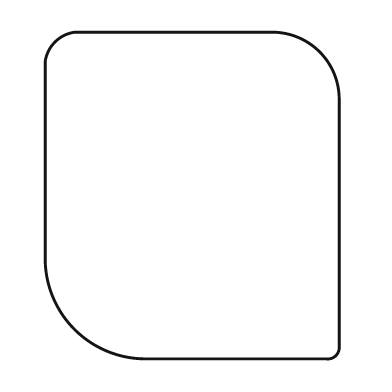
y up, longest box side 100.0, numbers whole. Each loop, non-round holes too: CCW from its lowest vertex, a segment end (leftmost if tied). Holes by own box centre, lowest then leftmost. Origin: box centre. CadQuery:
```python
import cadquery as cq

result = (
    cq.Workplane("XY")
    .moveTo(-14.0, -50.0)
    .lineTo(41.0, -50.0)
    .threePointArc((44.0, -49.0), (45.0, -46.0))
    .lineTo(45.0, 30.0)
    .threePointArc((39.0, 44.0), (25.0, 50.0))
    .lineTo(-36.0, 50.0)
    .threePointArc((-42.0, 47.0), (-45.0, 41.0))
    .lineTo(-45.0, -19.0)
    .threePointArc((-36.0, -41.0), (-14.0, -50.0))
    .close()
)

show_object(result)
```